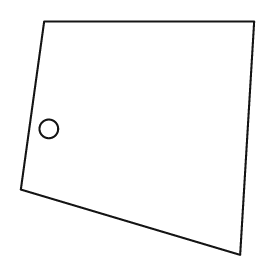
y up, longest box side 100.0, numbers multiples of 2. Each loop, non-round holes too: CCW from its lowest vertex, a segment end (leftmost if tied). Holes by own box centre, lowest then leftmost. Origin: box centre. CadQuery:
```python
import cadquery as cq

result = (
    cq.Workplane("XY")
    .moveTo(44.0, -50.0)
    .lineTo(50.0, 50.0)
    .lineTo(-40.0, 50.0)
    .lineTo(-50.0, -22.0)
    .close()
    .moveTo(-38.0, 4.0)
    .circle(4.0)
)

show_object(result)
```